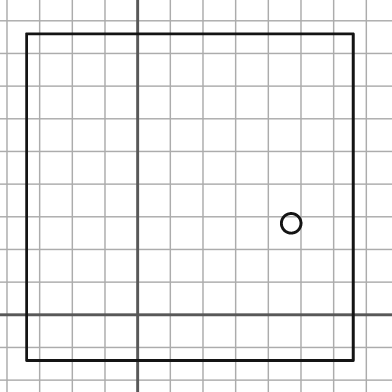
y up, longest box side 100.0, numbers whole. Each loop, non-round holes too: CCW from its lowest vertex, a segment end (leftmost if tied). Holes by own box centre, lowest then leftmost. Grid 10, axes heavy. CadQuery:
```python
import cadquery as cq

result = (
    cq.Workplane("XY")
    .moveTo(-34.0, -14.0)
    .lineTo(66.0, -14.0)
    .lineTo(66.0, 86.0)
    .lineTo(-34.0, 86.0)
    .close()
    .moveTo(47.0, 28.0)
    .circle(3.0)
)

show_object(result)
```